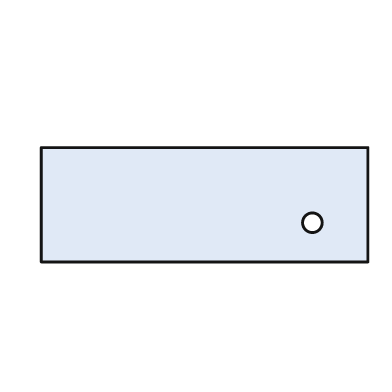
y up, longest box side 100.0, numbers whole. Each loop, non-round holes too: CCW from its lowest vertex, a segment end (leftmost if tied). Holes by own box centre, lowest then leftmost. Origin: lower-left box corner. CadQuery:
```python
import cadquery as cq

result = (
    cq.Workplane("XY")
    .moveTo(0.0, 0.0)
    .lineTo(100.0, 0.0)
    .lineTo(100.0, 35.0)
    .lineTo(0.0, 35.0)
    .close()
    .moveTo(83.0, 12.0)
    .circle(3.0)
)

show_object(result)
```